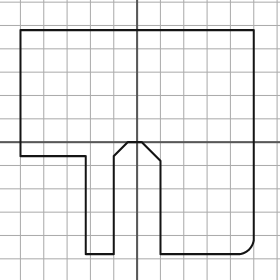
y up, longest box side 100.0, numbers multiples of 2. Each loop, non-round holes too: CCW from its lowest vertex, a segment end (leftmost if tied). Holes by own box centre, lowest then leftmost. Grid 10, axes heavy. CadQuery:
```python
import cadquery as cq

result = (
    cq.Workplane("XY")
    .moveTo(-22.0, -48.0)
    .lineTo(-10.0, -48.0)
    .lineTo(-10.0, -6.0)
    .lineTo(-4.0, 0.0)
    .lineTo(2.0, 0.0)
    .lineTo(10.0, -8.0)
    .lineTo(10.0, -48.0)
    .lineTo(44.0, -48.0)
    .threePointArc((48.0, -46.0), (50.0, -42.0))
    .lineTo(50.0, 48.0)
    .lineTo(-50.0, 48.0)
    .lineTo(-50.0, -6.0)
    .lineTo(-22.0, -6.0)
    .close()
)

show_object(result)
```